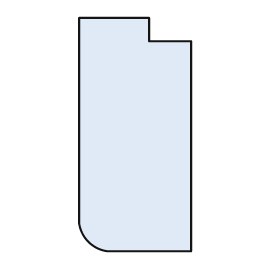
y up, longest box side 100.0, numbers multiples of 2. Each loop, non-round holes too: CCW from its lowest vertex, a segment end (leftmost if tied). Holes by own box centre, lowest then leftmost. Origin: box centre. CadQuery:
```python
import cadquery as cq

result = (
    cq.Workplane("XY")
    .moveTo(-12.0, -50.0)
    .lineTo(24.0, -50.0)
    .lineTo(24.0, 40.0)
    .lineTo(6.0, 40.0)
    .lineTo(6.0, 50.0)
    .lineTo(-24.0, 50.0)
    .lineTo(-24.0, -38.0)
    .threePointArc((-20.0, -46.0), (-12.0, -50.0))
    .close()
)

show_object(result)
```